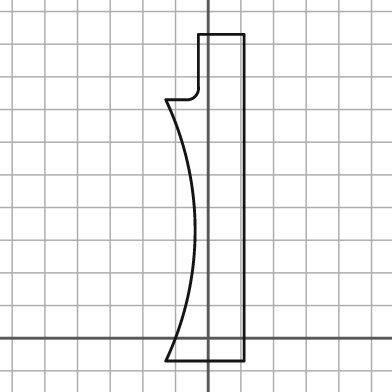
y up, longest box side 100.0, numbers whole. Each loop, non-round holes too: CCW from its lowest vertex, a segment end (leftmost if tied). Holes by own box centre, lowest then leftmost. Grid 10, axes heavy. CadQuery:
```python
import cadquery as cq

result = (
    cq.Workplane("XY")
    .moveTo(-13.0, -7.0)
    .lineTo(11.0, -7.0)
    .lineTo(11.0, 93.0)
    .lineTo(-3.0, 93.0)
    .lineTo(-3.0, 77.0)
    .threePointArc((-4.0, 74.0), (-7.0, 73.0))
    .lineTo(-13.0, 73.0)
    .threePointArc((-4.0, 33.0), (-13.0, -7.0))
    .close()
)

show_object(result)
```